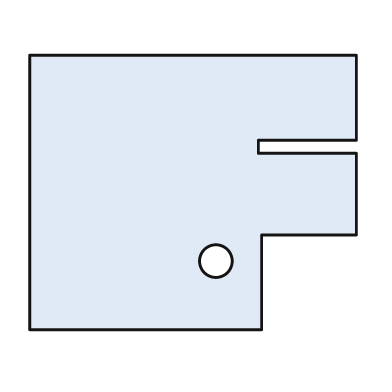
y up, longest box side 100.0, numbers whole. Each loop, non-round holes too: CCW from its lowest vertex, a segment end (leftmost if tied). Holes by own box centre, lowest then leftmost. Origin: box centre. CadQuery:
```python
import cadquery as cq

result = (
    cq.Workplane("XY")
    .moveTo(-50.0, -42.0)
    .lineTo(21.0, -42.0)
    .lineTo(21.0, -13.0)
    .lineTo(50.0, -13.0)
    .lineTo(50.0, 12.0)
    .lineTo(20.0, 12.0)
    .lineTo(20.0, 16.0)
    .lineTo(50.0, 16.0)
    .lineTo(50.0, 42.0)
    .lineTo(-50.0, 42.0)
    .close()
    .moveTo(7.0, -21.0)
    .circle(5.0)
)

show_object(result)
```